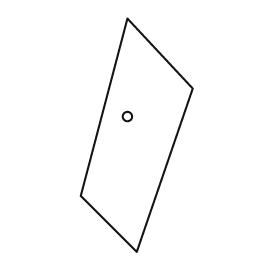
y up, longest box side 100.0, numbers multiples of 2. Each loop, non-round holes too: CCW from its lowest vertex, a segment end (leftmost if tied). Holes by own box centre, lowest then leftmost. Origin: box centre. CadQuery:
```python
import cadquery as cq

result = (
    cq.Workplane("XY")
    .moveTo(0.0, -50.0)
    .lineTo(24.0, 20.0)
    .lineTo(-4.0, 50.0)
    .lineTo(-24.0, -26.0)
    .close()
    .moveTo(-4.0, 8.0)
    .circle(2.0)
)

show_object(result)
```